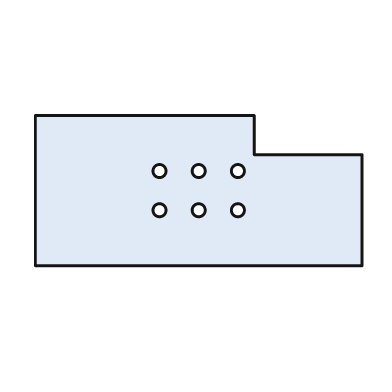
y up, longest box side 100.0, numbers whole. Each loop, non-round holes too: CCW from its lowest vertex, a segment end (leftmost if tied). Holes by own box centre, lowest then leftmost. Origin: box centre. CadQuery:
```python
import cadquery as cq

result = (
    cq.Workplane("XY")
    .moveTo(-50.0, -23.0)
    .lineTo(50.0, -23.0)
    .lineTo(50.0, 11.0)
    .lineTo(17.0, 11.0)
    .lineTo(17.0, 23.0)
    .lineTo(-50.0, 23.0)
    .close()
    .moveTo(-12.0, -6.0)
    .circle(2.0)
    .moveTo(0.0, -6.0)
    .circle(2.0)
    .moveTo(12.0, -6.0)
    .circle(2.0)
    .moveTo(-12.0, 6.0)
    .circle(2.0)
    .moveTo(0.0, 6.0)
    .circle(2.0)
    .moveTo(12.0, 6.0)
    .circle(2.0)
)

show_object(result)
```